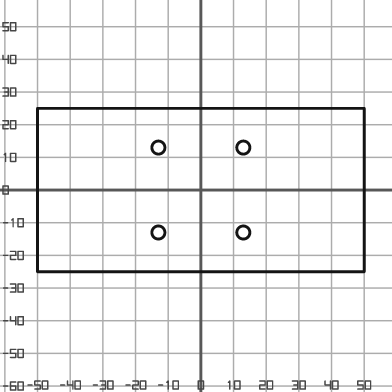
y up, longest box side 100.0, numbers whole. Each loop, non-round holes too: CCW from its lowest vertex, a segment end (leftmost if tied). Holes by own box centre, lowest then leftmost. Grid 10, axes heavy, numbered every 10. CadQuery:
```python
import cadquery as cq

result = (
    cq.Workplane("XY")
    .moveTo(-50.0, -25.0)
    .lineTo(50.0, -25.0)
    .lineTo(50.0, 25.0)
    .lineTo(-50.0, 25.0)
    .close()
    .moveTo(-13.0, -13.0)
    .circle(2.0)
    .moveTo(13.0, -13.0)
    .circle(2.0)
    .moveTo(-13.0, 13.0)
    .circle(2.0)
    .moveTo(13.0, 13.0)
    .circle(2.0)
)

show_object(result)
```